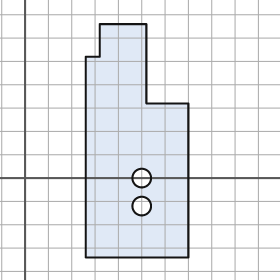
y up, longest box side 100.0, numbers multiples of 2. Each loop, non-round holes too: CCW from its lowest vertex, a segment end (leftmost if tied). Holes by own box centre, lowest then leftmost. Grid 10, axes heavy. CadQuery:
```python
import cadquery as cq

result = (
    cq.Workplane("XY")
    .moveTo(26.0, -34.0)
    .lineTo(70.0, -34.0)
    .lineTo(70.0, 32.0)
    .lineTo(52.0, 32.0)
    .lineTo(52.0, 66.0)
    .lineTo(32.0, 66.0)
    .lineTo(32.0, 52.0)
    .lineTo(26.0, 52.0)
    .close()
    .moveTo(50.0, -12.0)
    .circle(4.0)
    .moveTo(50.0, 0.0)
    .circle(4.0)
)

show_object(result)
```